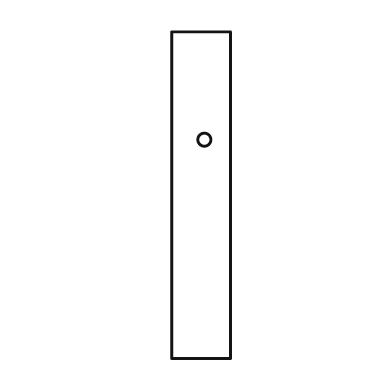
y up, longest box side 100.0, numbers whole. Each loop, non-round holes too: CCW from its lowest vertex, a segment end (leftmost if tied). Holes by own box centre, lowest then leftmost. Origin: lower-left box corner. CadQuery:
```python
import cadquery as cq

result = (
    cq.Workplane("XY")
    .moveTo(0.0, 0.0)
    .lineTo(18.0, 0.0)
    .lineTo(18.0, 100.0)
    .lineTo(0.0, 100.0)
    .close()
    .moveTo(10.0, 67.0)
    .circle(2.0)
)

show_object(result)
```